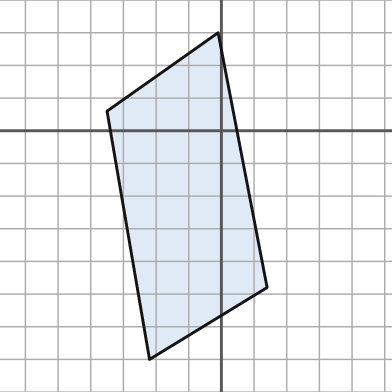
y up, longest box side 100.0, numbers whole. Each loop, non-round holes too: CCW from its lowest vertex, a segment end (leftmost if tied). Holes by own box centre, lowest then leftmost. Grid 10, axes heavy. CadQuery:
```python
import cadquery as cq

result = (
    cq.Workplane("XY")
    .moveTo(-22.0, -70.0)
    .lineTo(14.0, -48.0)
    .lineTo(-1.0, 30.0)
    .lineTo(-35.0, 6.0)
    .close()
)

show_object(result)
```